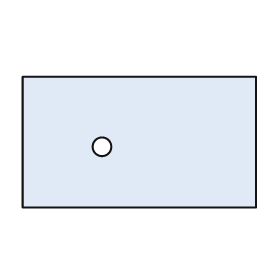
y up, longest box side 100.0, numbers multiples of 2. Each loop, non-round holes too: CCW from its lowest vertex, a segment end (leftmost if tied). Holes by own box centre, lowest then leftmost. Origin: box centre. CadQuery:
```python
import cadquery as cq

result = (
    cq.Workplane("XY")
    .moveTo(-50.0, -28.0)
    .lineTo(50.0, -28.0)
    .lineTo(50.0, 28.0)
    .lineTo(-50.0, 28.0)
    .close()
    .moveTo(-16.0, -2.0)
    .circle(4.0)
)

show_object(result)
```